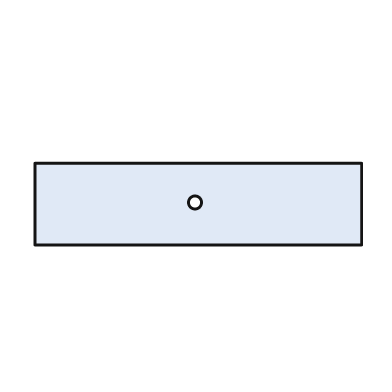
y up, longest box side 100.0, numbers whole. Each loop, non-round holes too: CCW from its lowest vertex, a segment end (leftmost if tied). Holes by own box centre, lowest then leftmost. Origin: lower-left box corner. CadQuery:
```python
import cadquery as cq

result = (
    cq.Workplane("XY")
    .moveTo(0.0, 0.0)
    .lineTo(100.0, 0.0)
    .lineTo(100.0, 25.0)
    .lineTo(0.0, 25.0)
    .close()
    .moveTo(49.0, 13.0)
    .circle(2.0)
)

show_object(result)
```